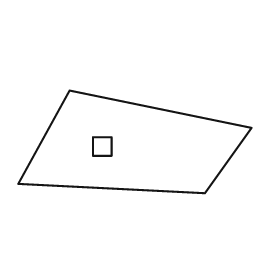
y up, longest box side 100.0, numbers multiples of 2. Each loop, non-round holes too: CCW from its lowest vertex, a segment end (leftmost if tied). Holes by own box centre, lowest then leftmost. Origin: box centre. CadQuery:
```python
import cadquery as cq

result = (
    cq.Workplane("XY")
    .moveTo(30.0, -22.0)
    .lineTo(50.0, 6.0)
    .lineTo(-28.0, 22.0)
    .lineTo(-50.0, -18.0)
    .close()
    .moveTo(-18.0, -6.0)
    .lineTo(-10.0, -6.0)
    .lineTo(-10.0, 2.0)
    .lineTo(-18.0, 2.0)
    .close()
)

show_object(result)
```